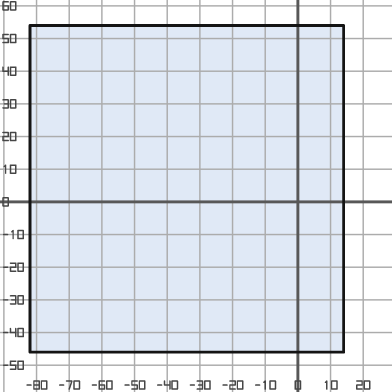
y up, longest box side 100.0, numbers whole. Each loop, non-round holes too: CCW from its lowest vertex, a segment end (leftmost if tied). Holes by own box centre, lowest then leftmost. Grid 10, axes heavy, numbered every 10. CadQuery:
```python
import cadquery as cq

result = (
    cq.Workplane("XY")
    .moveTo(-82.0, -46.0)
    .lineTo(14.0, -46.0)
    .lineTo(14.0, 54.0)
    .lineTo(-82.0, 54.0)
    .close()
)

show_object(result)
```